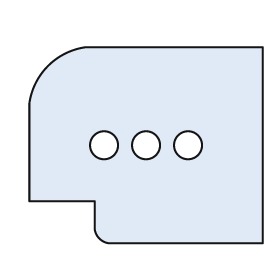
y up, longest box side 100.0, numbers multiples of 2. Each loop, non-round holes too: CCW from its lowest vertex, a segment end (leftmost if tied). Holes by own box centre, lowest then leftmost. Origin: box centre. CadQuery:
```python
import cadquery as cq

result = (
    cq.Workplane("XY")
    .moveTo(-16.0, -42.0)
    .lineTo(50.0, -42.0)
    .lineTo(50.0, 42.0)
    .lineTo(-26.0, 42.0)
    .threePointArc((-42.0, 34.0), (-50.0, 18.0))
    .lineTo(-50.0, -24.0)
    .lineTo(-22.0, -24.0)
    .lineTo(-22.0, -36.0)
    .threePointArc((-20.0, -40.0), (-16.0, -42.0))
    .close()
    .moveTo(-18.0, 0.0)
    .circle(6.0)
    .moveTo(0.0, 0.0)
    .circle(6.0)
    .moveTo(18.0, 0.0)
    .circle(6.0)
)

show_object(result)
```